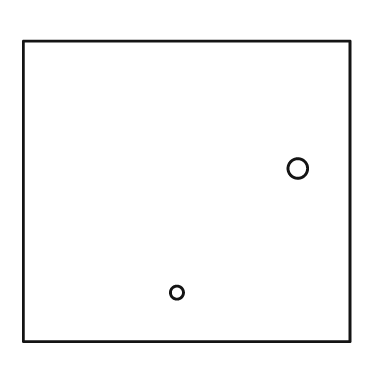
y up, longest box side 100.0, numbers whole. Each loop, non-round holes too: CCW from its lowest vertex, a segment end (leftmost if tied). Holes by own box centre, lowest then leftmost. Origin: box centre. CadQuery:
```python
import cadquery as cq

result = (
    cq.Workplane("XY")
    .moveTo(-50.0, -46.0)
    .lineTo(50.0, -46.0)
    .lineTo(50.0, 46.0)
    .lineTo(-50.0, 46.0)
    .close()
    .moveTo(-3.0, -31.0)
    .circle(2.0)
    .moveTo(34.0, 7.0)
    .circle(3.0)
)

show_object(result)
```